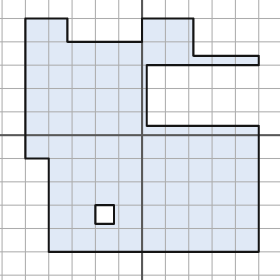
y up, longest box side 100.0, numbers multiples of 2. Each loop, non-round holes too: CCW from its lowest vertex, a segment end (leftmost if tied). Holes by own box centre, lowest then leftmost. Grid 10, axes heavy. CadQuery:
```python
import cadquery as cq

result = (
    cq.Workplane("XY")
    .moveTo(-40.0, -50.0)
    .lineTo(50.0, -50.0)
    .lineTo(50.0, 4.0)
    .lineTo(2.0, 4.0)
    .lineTo(2.0, 30.0)
    .lineTo(50.0, 30.0)
    .lineTo(50.0, 34.0)
    .lineTo(22.0, 34.0)
    .lineTo(22.0, 50.0)
    .lineTo(0.0, 50.0)
    .lineTo(0.0, 40.0)
    .lineTo(-32.0, 40.0)
    .lineTo(-32.0, 50.0)
    .lineTo(-50.0, 50.0)
    .lineTo(-50.0, -10.0)
    .lineTo(-40.0, -10.0)
    .close()
    .moveTo(-20.0, -38.0)
    .lineTo(-12.0, -38.0)
    .lineTo(-12.0, -30.0)
    .lineTo(-20.0, -30.0)
    .close()
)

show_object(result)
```